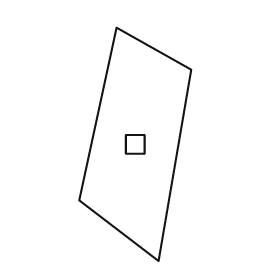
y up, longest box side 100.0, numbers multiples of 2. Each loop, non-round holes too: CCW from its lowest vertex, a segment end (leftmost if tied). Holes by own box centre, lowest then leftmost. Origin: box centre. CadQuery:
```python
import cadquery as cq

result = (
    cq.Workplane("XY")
    .moveTo(10.0, -50.0)
    .lineTo(24.0, 32.0)
    .lineTo(-8.0, 50.0)
    .lineTo(-24.0, -24.0)
    .close()
    .moveTo(-4.0, -4.0)
    .lineTo(4.0, -4.0)
    .lineTo(4.0, 4.0)
    .lineTo(-4.0, 4.0)
    .close()
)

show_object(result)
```